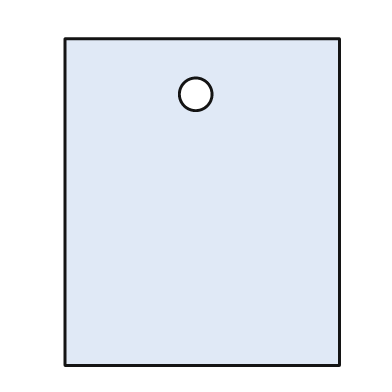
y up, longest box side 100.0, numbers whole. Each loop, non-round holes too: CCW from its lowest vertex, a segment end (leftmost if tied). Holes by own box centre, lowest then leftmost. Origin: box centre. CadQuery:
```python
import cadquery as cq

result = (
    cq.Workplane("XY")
    .moveTo(-42.0, -50.0)
    .lineTo(42.0, -50.0)
    .lineTo(42.0, 50.0)
    .lineTo(-42.0, 50.0)
    .close()
    .moveTo(-2.0, 33.0)
    .circle(5.0)
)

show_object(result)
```